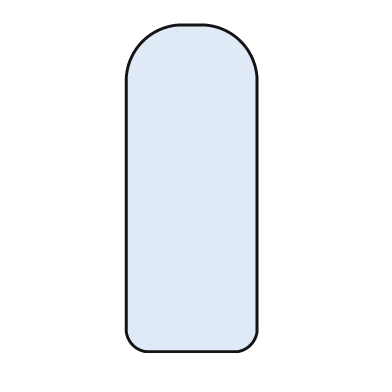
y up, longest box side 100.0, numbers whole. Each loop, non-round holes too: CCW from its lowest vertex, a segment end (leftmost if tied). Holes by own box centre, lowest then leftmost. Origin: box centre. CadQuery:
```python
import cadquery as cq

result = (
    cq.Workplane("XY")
    .moveTo(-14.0, -50.0)
    .lineTo(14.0, -50.0)
    .threePointArc((18.0, -48.0), (20.0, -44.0))
    .lineTo(20.0, 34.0)
    .threePointArc((15.0, 45.0), (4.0, 50.0))
    .lineTo(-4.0, 50.0)
    .threePointArc((-15.0, 45.0), (-20.0, 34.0))
    .lineTo(-20.0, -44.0)
    .threePointArc((-18.0, -48.0), (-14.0, -50.0))
    .close()
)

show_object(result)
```